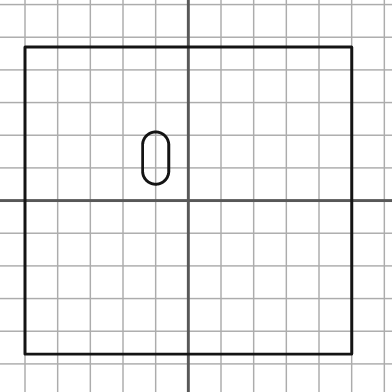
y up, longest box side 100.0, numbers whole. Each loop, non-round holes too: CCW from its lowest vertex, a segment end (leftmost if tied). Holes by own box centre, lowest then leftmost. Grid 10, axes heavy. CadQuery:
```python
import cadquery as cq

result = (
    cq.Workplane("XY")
    .moveTo(-50.0, -47.0)
    .lineTo(50.0, -47.0)
    .lineTo(50.0, 47.0)
    .lineTo(-50.0, 47.0)
    .close()
    .moveTo(-14.0, 9.0)
    .threePointArc((-10.0, 5.0), (-6.0, 9.0))
    .lineTo(-6.0, 17.0)
    .threePointArc((-10.0, 21.0), (-14.0, 17.0))
    .close()
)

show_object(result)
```